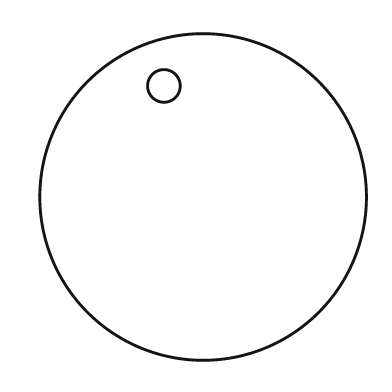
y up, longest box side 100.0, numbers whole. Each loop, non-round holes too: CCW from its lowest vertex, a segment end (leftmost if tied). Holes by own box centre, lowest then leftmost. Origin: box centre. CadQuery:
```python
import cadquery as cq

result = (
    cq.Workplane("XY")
    .moveTo(0.0, 0.0)
    .circle(50.0)
    .moveTo(-12.0, 34.0)
    .circle(5.0)
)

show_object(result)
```